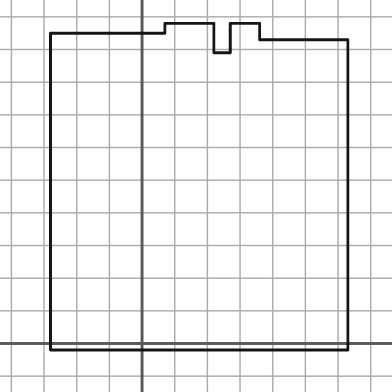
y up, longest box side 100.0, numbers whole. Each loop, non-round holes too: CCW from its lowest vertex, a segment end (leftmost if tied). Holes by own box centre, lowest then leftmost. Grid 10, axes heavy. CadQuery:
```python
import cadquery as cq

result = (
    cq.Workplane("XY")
    .moveTo(-28.0, -2.0)
    .lineTo(63.0, -2.0)
    .lineTo(63.0, 93.0)
    .lineTo(36.0, 93.0)
    .lineTo(36.0, 98.0)
    .lineTo(27.0, 98.0)
    .lineTo(27.0, 89.0)
    .lineTo(22.0, 89.0)
    .lineTo(22.0, 98.0)
    .lineTo(7.0, 98.0)
    .lineTo(7.0, 95.0)
    .lineTo(-28.0, 95.0)
    .close()
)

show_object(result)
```